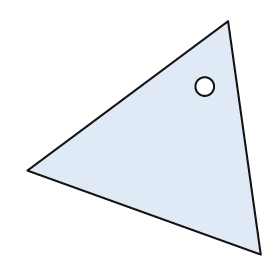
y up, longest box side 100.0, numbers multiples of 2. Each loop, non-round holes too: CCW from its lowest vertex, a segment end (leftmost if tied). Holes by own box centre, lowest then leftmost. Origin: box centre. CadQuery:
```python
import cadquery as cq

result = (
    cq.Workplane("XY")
    .moveTo(50.0, -50.0)
    .lineTo(36.0, 50.0)
    .lineTo(-50.0, -14.0)
    .close()
    .moveTo(26.0, 22.0)
    .circle(4.0)
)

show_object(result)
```